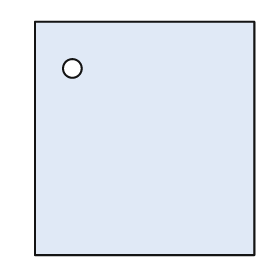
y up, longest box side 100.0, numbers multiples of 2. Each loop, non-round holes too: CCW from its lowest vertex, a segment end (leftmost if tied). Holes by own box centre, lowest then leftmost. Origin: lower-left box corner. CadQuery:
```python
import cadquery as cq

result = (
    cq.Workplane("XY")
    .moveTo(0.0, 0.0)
    .lineTo(94.0, 0.0)
    .lineTo(94.0, 100.0)
    .lineTo(0.0, 100.0)
    .close()
    .moveTo(16.0, 80.0)
    .circle(4.0)
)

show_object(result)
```